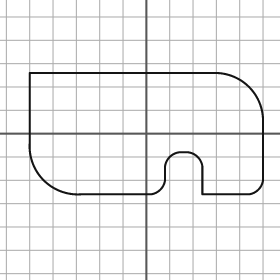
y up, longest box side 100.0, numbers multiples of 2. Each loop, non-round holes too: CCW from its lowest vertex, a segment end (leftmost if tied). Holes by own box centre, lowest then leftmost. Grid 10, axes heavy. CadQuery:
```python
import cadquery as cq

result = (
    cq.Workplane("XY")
    .moveTo(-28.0, -26.0)
    .lineTo(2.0, -26.0)
    .threePointArc((6.0, -24.0), (8.0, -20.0))
    .lineTo(8.0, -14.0)
    .threePointArc((10.0, -10.0), (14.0, -8.0))
    .lineTo(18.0, -8.0)
    .threePointArc((22.0, -10.0), (24.0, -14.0))
    .lineTo(24.0, -26.0)
    .lineTo(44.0, -26.0)
    .threePointArc((48.0, -24.0), (50.0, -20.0))
    .lineTo(50.0, 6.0)
    .threePointArc((44.0, 20.0), (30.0, 26.0))
    .lineTo(-50.0, 26.0)
    .lineTo(-50.0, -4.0)
    .threePointArc((-44.0, -20.0), (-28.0, -26.0))
    .close()
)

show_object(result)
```